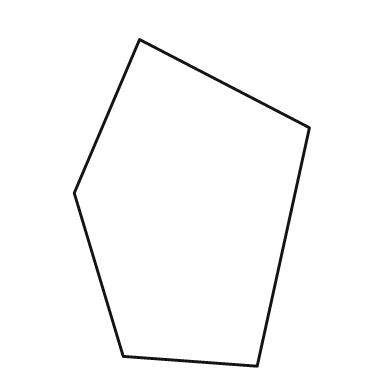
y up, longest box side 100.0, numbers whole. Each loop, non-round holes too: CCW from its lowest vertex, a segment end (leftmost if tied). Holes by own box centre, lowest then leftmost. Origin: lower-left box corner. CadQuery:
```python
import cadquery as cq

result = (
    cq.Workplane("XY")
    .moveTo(56.0, 0.0)
    .lineTo(72.0, 73.0)
    .lineTo(20.0, 100.0)
    .lineTo(0.0, 53.0)
    .lineTo(15.0, 3.0)
    .close()
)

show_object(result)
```